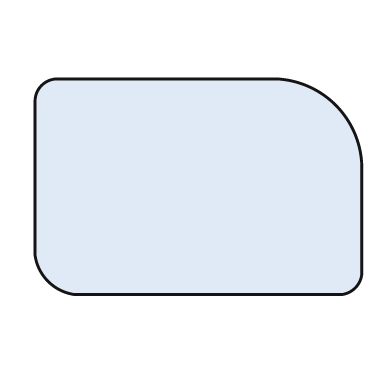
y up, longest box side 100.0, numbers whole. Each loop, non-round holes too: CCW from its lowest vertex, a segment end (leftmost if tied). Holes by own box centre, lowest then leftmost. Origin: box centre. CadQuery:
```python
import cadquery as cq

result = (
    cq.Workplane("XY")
    .moveTo(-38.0, -33.0)
    .lineTo(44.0, -33.0)
    .threePointArc((48.0, -31.0), (50.0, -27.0))
    .lineTo(50.0, 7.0)
    .threePointArc((42.0, 25.0), (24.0, 33.0))
    .lineTo(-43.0, 33.0)
    .threePointArc((-48.0, 31.0), (-50.0, 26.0))
    .lineTo(-50.0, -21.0)
    .threePointArc((-46.0, -29.0), (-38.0, -33.0))
    .close()
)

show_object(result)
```